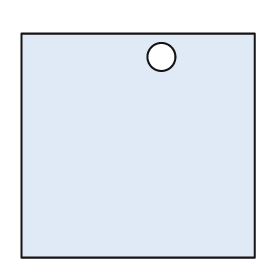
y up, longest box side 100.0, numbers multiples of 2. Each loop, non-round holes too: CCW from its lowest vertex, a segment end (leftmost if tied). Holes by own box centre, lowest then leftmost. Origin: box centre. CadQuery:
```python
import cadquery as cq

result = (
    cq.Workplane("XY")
    .moveTo(-50.0, -48.0)
    .lineTo(50.0, -48.0)
    .lineTo(50.0, 48.0)
    .lineTo(-50.0, 48.0)
    .close()
    .moveTo(10.0, 38.0)
    .circle(6.0)
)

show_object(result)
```